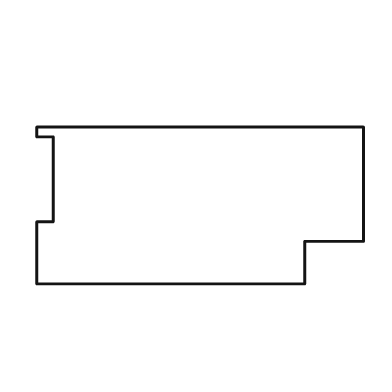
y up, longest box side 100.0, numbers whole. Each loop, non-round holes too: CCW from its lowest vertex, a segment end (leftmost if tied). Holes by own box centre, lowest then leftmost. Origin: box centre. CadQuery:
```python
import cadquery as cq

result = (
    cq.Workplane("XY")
    .moveTo(-50.0, -24.0)
    .lineTo(32.0, -24.0)
    .lineTo(32.0, -11.0)
    .lineTo(50.0, -11.0)
    .lineTo(50.0, 24.0)
    .lineTo(-50.0, 24.0)
    .lineTo(-50.0, 21.0)
    .lineTo(-45.0, 21.0)
    .lineTo(-45.0, -5.0)
    .lineTo(-50.0, -5.0)
    .close()
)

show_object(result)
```